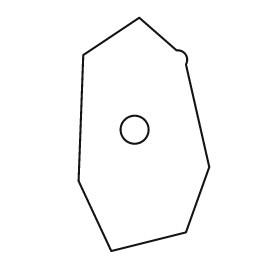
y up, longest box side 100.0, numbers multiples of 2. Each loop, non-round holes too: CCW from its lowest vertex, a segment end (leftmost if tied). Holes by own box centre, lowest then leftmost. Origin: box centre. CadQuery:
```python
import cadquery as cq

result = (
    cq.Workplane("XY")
    .moveTo(-14.0, -50.0)
    .lineTo(18.0, -42.0)
    .lineTo(28.0, -14.0)
    .lineTo(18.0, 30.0)
    .threePointArc((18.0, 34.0), (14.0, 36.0))
    .lineTo(-2.0, 50.0)
    .lineTo(-26.0, 34.0)
    .lineTo(-28.0, -20.0)
    .close()
    .moveTo(-4.0, 2.0)
    .circle(6.0)
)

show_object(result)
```